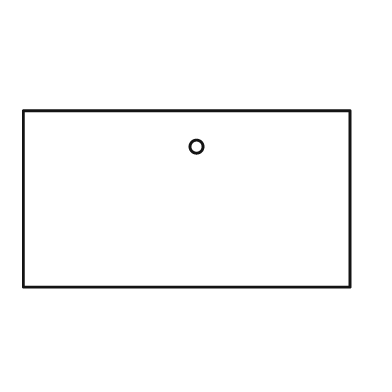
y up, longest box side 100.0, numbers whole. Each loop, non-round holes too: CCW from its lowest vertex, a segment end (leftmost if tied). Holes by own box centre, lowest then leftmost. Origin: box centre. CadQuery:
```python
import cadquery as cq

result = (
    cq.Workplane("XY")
    .moveTo(-50.0, -27.0)
    .lineTo(50.0, -27.0)
    .lineTo(50.0, 27.0)
    .lineTo(-50.0, 27.0)
    .close()
    .moveTo(3.0, 16.0)
    .circle(2.0)
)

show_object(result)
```